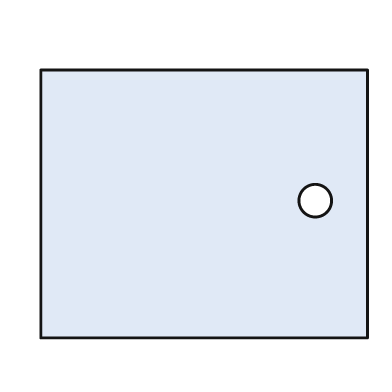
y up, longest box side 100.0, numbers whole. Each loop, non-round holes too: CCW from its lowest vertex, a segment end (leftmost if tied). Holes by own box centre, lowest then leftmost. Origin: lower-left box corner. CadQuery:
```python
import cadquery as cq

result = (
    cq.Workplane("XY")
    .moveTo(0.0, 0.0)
    .lineTo(100.0, 0.0)
    .lineTo(100.0, 82.0)
    .lineTo(0.0, 82.0)
    .close()
    .moveTo(84.0, 42.0)
    .circle(5.0)
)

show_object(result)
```